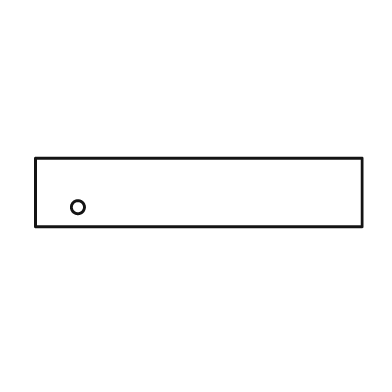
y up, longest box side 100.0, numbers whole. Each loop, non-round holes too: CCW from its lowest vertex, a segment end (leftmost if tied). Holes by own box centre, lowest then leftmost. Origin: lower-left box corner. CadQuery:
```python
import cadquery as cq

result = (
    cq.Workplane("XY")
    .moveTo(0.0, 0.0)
    .lineTo(100.0, 0.0)
    .lineTo(100.0, 21.0)
    .lineTo(0.0, 21.0)
    .close()
    .moveTo(13.0, 6.0)
    .circle(2.0)
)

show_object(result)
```